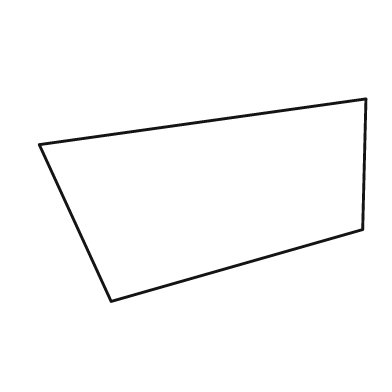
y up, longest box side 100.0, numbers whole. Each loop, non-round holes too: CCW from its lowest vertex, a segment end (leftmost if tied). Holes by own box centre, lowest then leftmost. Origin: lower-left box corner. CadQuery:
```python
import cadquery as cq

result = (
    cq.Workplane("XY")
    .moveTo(22.0, 0.0)
    .lineTo(99.0, 22.0)
    .lineTo(100.0, 62.0)
    .lineTo(0.0, 48.0)
    .close()
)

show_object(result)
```